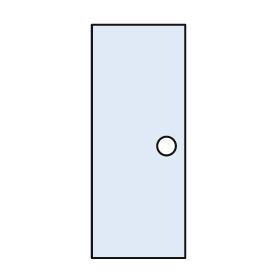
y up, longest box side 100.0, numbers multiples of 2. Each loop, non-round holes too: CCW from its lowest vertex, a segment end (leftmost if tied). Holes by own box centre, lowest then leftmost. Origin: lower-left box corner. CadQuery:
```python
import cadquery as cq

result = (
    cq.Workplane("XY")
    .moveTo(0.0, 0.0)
    .lineTo(40.0, 0.0)
    .lineTo(40.0, 100.0)
    .lineTo(0.0, 100.0)
    .close()
    .moveTo(32.0, 48.0)
    .circle(4.0)
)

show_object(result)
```